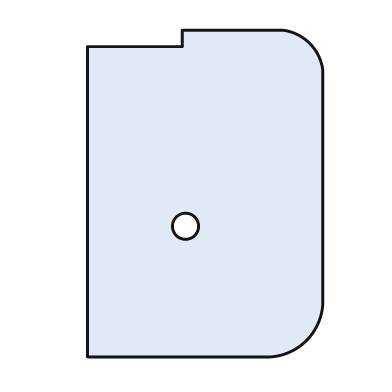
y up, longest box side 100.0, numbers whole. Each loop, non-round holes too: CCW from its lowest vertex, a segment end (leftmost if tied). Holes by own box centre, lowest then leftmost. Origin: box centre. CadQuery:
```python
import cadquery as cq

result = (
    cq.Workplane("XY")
    .moveTo(-36.0, -50.0)
    .lineTo(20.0, -50.0)
    .threePointArc((31.0, -45.0), (36.0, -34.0))
    .lineTo(36.0, 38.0)
    .threePointArc((32.0, 46.0), (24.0, 50.0))
    .lineTo(-7.0, 50.0)
    .lineTo(-7.0, 45.0)
    .lineTo(-36.0, 45.0)
    .close()
    .moveTo(-6.0, -10.0)
    .circle(4.0)
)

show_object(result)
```